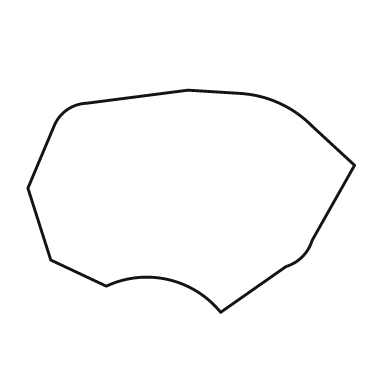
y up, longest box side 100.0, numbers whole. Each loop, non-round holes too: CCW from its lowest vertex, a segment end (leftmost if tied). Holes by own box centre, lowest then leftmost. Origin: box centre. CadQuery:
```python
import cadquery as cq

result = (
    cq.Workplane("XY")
    .moveTo(9.0, -34.0)
    .lineTo(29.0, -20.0)
    .threePointArc((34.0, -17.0), (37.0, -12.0))
    .lineTo(50.0, 11.0)
    .lineTo(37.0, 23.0)
    .threePointArc((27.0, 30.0), (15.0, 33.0))
    .lineTo(-1.0, 34.0)
    .lineTo(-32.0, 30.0)
    .threePointArc((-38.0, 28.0), (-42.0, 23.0))
    .lineTo(-50.0, 4.0)
    .lineTo(-43.0, -18.0)
    .lineTo(-26.0, -26.0)
    .threePointArc((-7.0, -24.0), (9.0, -34.0))
    .close()
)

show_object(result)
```